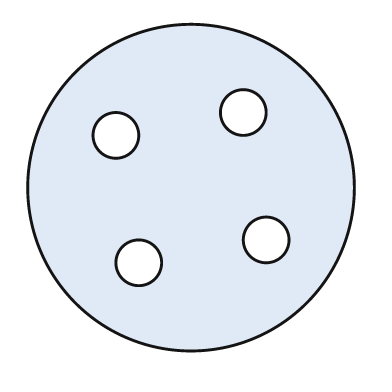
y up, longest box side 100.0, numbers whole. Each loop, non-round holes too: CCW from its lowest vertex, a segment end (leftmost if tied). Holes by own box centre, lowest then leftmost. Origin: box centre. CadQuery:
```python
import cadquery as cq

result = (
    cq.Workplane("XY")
    .moveTo(0.0, 0.0)
    .circle(50.0)
    .moveTo(-16.0, -23.0)
    .circle(7.0)
    .moveTo(23.0, -16.0)
    .circle(7.0)
    .moveTo(-23.0, 16.0)
    .circle(7.0)
    .moveTo(16.0, 23.0)
    .circle(7.0)
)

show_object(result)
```